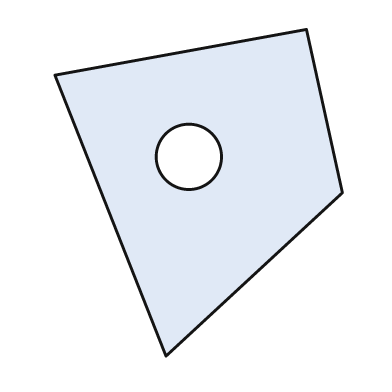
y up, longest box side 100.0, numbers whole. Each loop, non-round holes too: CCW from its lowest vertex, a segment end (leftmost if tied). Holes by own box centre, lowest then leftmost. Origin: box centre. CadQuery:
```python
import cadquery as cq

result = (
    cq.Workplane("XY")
    .moveTo(-10.0, -50.0)
    .lineTo(44.0, 0.0)
    .lineTo(33.0, 50.0)
    .lineTo(-44.0, 36.0)
    .close()
    .moveTo(-3.0, 11.0)
    .circle(10.0)
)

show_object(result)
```